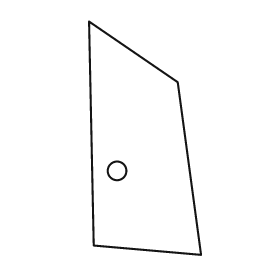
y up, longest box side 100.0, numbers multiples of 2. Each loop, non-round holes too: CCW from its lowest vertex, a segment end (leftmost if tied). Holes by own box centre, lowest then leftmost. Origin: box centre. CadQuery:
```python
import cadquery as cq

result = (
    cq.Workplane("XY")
    .moveTo(24.0, -50.0)
    .lineTo(14.0, 24.0)
    .lineTo(-24.0, 50.0)
    .lineTo(-22.0, -46.0)
    .close()
    .moveTo(-12.0, -14.0)
    .circle(4.0)
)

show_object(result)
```